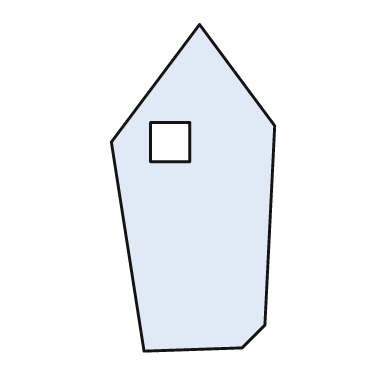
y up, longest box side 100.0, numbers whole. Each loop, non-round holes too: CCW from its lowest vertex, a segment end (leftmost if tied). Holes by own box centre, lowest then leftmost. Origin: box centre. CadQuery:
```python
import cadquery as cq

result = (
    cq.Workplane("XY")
    .moveTo(-15.0, -50.0)
    .lineTo(15.0, -49.0)
    .lineTo(22.0, -42.0)
    .lineTo(25.0, 19.0)
    .lineTo(2.0, 50.0)
    .lineTo(-25.0, 14.0)
    .close()
    .moveTo(-13.0, 8.0)
    .lineTo(-1.0, 8.0)
    .lineTo(-1.0, 20.0)
    .lineTo(-13.0, 20.0)
    .close()
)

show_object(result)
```